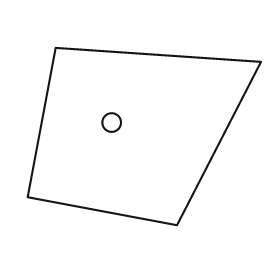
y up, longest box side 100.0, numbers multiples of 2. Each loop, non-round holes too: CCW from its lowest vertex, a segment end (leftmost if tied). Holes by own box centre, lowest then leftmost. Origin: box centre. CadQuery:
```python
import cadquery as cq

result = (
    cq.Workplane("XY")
    .moveTo(14.0, -38.0)
    .lineTo(50.0, 32.0)
    .lineTo(-38.0, 38.0)
    .lineTo(-50.0, -26.0)
    .close()
    .moveTo(-14.0, 6.0)
    .circle(4.0)
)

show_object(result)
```